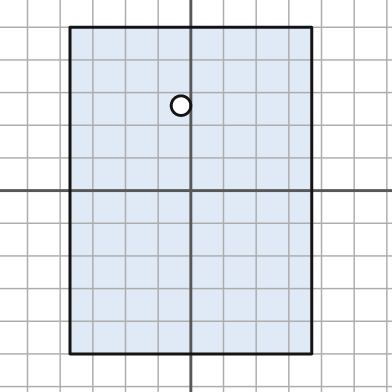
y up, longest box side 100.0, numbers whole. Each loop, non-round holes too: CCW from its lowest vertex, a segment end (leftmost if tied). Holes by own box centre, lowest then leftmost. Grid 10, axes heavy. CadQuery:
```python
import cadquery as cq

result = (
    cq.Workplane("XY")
    .moveTo(-37.0, -50.0)
    .lineTo(37.0, -50.0)
    .lineTo(37.0, 50.0)
    .lineTo(-37.0, 50.0)
    .close()
    .moveTo(-3.0, 26.0)
    .circle(3.0)
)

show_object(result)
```